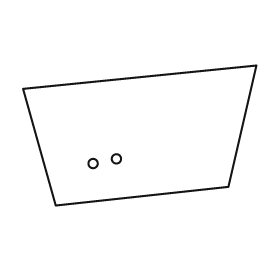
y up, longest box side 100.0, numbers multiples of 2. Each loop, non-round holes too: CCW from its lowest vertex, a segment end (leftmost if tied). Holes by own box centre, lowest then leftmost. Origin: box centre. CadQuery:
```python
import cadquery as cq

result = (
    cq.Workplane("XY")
    .moveTo(-36.0, -30.0)
    .lineTo(38.0, -22.0)
    .lineTo(50.0, 30.0)
    .lineTo(-50.0, 20.0)
    .close()
    .moveTo(-20.0, -12.0)
    .circle(2.0)
    .moveTo(-10.0, -10.0)
    .circle(2.0)
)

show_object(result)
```